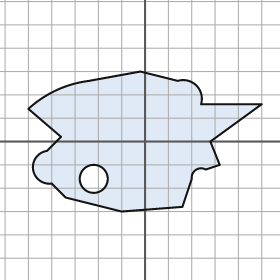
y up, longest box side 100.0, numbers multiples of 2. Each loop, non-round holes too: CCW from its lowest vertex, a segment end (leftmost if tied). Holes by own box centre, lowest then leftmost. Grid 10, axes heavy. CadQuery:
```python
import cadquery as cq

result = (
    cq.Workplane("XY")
    .moveTo(-10.0, -30.0)
    .lineTo(16.0, -28.0)
    .lineTo(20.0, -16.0)
    .threePointArc((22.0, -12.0), (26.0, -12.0))
    .lineTo(32.0, -10.0)
    .lineTo(28.0, 0.0)
    .lineTo(50.0, 16.0)
    .lineTo(24.0, 16.0)
    .threePointArc((22.0, 24.0), (14.0, 26.0))
    .lineTo(-2.0, 30.0)
    .lineTo(-24.0, 26.0)
    .threePointArc((-38.0, 22.0), (-50.0, 14.0))
    .lineTo(-36.0, 2.0)
    .lineTo(-42.0, -4.0)
    .threePointArc((-48.0, -12.0), (-40.0, -18.0))
    .lineTo(-34.0, -24.0)
    .close()
    .moveTo(-22.0, -16.0)
    .circle(6.0)
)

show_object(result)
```